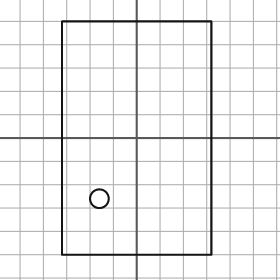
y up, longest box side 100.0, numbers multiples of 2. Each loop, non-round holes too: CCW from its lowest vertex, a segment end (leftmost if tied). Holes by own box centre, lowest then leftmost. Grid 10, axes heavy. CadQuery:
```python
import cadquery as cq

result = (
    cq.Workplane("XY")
    .moveTo(-32.0, -50.0)
    .lineTo(32.0, -50.0)
    .lineTo(32.0, 50.0)
    .lineTo(-32.0, 50.0)
    .close()
    .moveTo(-16.0, -26.0)
    .circle(4.0)
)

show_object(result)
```